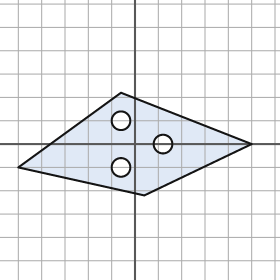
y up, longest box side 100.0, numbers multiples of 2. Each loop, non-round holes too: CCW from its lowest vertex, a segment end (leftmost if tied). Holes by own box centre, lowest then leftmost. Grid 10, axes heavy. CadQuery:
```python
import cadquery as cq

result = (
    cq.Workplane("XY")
    .moveTo(4.0, -22.0)
    .lineTo(50.0, 0.0)
    .lineTo(-6.0, 22.0)
    .lineTo(-50.0, -10.0)
    .close()
    .moveTo(-6.0, -10.0)
    .circle(4.0)
    .moveTo(12.0, 0.0)
    .circle(4.0)
    .moveTo(-6.0, 10.0)
    .circle(4.0)
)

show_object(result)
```